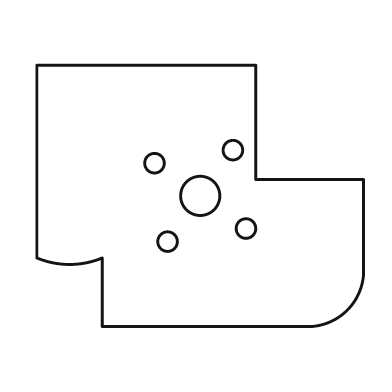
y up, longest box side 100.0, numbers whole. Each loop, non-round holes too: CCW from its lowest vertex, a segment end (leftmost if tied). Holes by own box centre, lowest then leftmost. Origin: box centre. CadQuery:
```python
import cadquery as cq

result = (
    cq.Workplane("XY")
    .moveTo(-30.0, -40.0)
    .lineTo(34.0, -40.0)
    .threePointArc((45.0, -35.0), (50.0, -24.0))
    .lineTo(50.0, 5.0)
    .lineTo(17.0, 5.0)
    .lineTo(17.0, 40.0)
    .lineTo(-50.0, 40.0)
    .lineTo(-50.0, -19.0)
    .threePointArc((-40.0, -21.0), (-30.0, -19.0))
    .close()
    .moveTo(-10.0, -14.0)
    .circle(3.0)
    .moveTo(14.0, -10.0)
    .circle(3.0)
    .moveTo(0.0, 0.0)
    .circle(6.0)
    .moveTo(-14.0, 10.0)
    .circle(3.0)
    .moveTo(10.0, 14.0)
    .circle(3.0)
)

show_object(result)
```